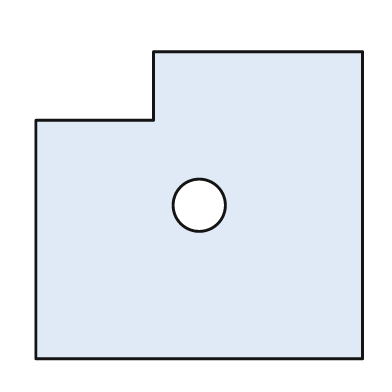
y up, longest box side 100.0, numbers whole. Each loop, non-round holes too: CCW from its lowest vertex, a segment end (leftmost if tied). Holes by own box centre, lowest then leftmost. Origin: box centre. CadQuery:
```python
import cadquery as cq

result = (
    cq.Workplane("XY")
    .moveTo(-50.0, -47.0)
    .lineTo(50.0, -47.0)
    .lineTo(50.0, 47.0)
    .lineTo(-14.0, 47.0)
    .lineTo(-14.0, 26.0)
    .lineTo(-50.0, 26.0)
    .close()
    .moveTo(0.0, 0.0)
    .circle(8.0)
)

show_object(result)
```